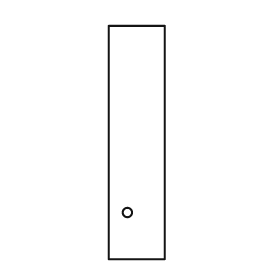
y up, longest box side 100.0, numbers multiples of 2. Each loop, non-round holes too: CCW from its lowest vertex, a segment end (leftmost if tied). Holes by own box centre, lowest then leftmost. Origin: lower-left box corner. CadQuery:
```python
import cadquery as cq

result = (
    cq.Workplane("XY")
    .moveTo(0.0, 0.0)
    .lineTo(24.0, 0.0)
    .lineTo(24.0, 100.0)
    .lineTo(0.0, 100.0)
    .close()
    .moveTo(8.0, 20.0)
    .circle(2.0)
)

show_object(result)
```